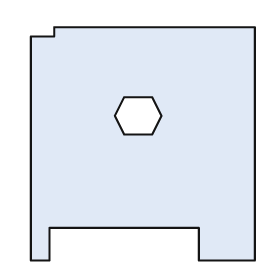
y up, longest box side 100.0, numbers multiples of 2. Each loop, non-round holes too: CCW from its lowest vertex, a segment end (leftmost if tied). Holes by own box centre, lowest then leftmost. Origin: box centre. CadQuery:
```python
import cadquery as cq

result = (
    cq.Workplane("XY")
    .moveTo(-48.0, -50.0)
    .lineTo(-40.0, -50.0)
    .lineTo(-40.0, -36.0)
    .lineTo(24.0, -36.0)
    .lineTo(24.0, -50.0)
    .lineTo(48.0, -50.0)
    .lineTo(48.0, 50.0)
    .lineTo(-38.0, 50.0)
    .lineTo(-38.0, 46.0)
    .lineTo(-48.0, 46.0)
    .close()
    .moveTo(-8.0, 4.0)
    .lineTo(4.0, 4.0)
    .lineTo(8.0, 12.0)
    .lineTo(4.0, 20.0)
    .lineTo(-8.0, 20.0)
    .lineTo(-12.0, 12.0)
    .close()
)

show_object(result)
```